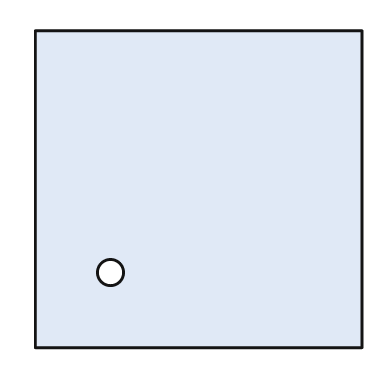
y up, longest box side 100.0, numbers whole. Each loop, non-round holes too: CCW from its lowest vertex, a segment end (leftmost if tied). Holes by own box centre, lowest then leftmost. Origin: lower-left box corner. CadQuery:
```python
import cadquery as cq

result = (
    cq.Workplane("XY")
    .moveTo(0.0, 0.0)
    .lineTo(100.0, 0.0)
    .lineTo(100.0, 97.0)
    .lineTo(0.0, 97.0)
    .close()
    .moveTo(23.0, 23.0)
    .circle(4.0)
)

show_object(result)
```